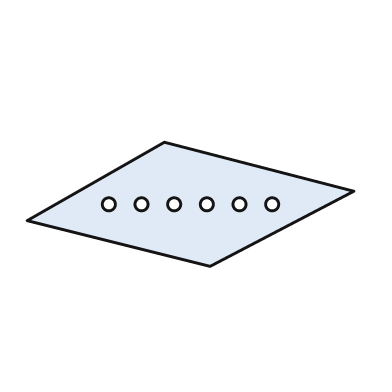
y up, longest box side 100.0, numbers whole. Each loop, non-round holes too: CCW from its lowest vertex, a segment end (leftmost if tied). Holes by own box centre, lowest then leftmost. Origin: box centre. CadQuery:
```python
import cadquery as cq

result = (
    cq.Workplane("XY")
    .moveTo(6.0, -19.0)
    .lineTo(50.0, 4.0)
    .lineTo(-8.0, 19.0)
    .lineTo(-50.0, -5.0)
    .close()
    .moveTo(-25.0, 0.0)
    .circle(2.0)
    .moveTo(-15.0, 0.0)
    .circle(2.0)
    .moveTo(-5.0, 0.0)
    .circle(2.0)
    .moveTo(5.0, 0.0)
    .circle(2.0)
    .moveTo(15.0, 0.0)
    .circle(2.0)
    .moveTo(25.0, 0.0)
    .circle(2.0)
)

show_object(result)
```